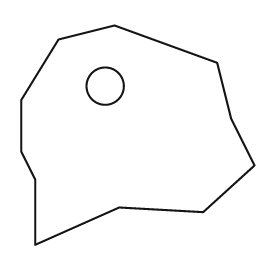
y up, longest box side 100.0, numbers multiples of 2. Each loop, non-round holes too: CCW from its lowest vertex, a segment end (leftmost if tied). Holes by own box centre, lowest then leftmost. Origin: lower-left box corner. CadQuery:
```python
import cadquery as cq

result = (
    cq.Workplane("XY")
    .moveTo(6.0, 0.0)
    .lineTo(42.0, 16.0)
    .lineTo(78.0, 14.0)
    .lineTo(100.0, 34.0)
    .lineTo(90.0, 54.0)
    .lineTo(84.0, 78.0)
    .lineTo(40.0, 94.0)
    .lineTo(16.0, 88.0)
    .lineTo(0.0, 62.0)
    .lineTo(0.0, 40.0)
    .lineTo(6.0, 28.0)
    .close()
    .moveTo(36.0, 68.0)
    .circle(8.0)
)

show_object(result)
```